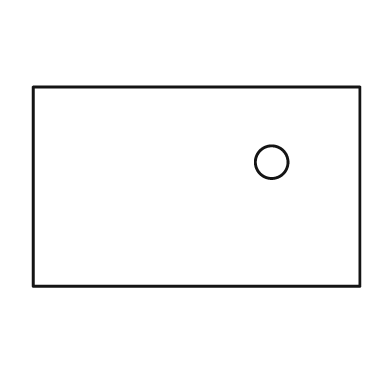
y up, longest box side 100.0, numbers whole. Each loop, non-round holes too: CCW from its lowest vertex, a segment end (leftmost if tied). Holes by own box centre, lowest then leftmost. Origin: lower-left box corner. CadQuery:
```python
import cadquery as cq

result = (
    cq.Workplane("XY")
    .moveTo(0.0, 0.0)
    .lineTo(100.0, 0.0)
    .lineTo(100.0, 61.0)
    .lineTo(0.0, 61.0)
    .close()
    .moveTo(73.0, 38.0)
    .circle(5.0)
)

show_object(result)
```